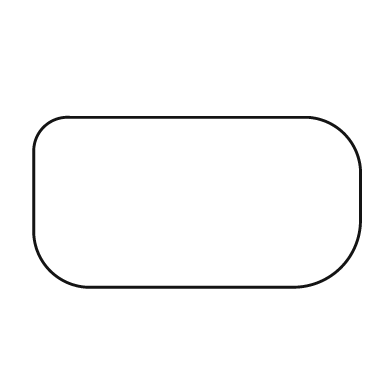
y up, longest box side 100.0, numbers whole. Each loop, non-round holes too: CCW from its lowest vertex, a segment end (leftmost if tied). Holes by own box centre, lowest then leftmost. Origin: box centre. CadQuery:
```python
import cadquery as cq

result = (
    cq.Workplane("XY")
    .moveTo(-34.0, -26.0)
    .lineTo(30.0, -26.0)
    .threePointArc((44.0, -20.0), (50.0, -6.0))
    .lineTo(50.0, 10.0)
    .threePointArc((45.0, 21.0), (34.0, 26.0))
    .lineTo(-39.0, 26.0)
    .threePointArc((-47.0, 23.0), (-50.0, 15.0))
    .lineTo(-50.0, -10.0)
    .threePointArc((-45.0, -21.0), (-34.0, -26.0))
    .close()
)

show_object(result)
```